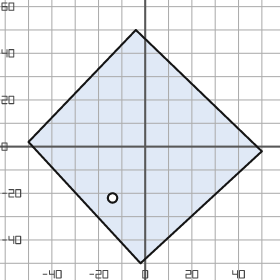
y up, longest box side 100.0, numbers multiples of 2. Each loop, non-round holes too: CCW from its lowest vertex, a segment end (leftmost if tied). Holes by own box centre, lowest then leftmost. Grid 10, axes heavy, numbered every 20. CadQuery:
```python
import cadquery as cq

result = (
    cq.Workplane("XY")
    .moveTo(-2.0, -50.0)
    .lineTo(50.0, -2.0)
    .lineTo(-4.0, 50.0)
    .lineTo(-50.0, 2.0)
    .close()
    .moveTo(-14.0, -22.0)
    .circle(2.0)
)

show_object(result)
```